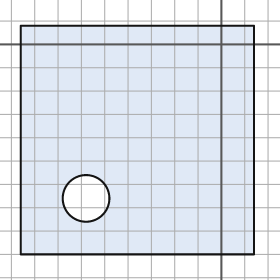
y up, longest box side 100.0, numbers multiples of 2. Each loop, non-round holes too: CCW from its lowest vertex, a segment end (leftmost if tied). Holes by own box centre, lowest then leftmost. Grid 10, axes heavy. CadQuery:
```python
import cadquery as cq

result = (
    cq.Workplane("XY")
    .moveTo(-86.0, -90.0)
    .lineTo(14.0, -90.0)
    .lineTo(14.0, 8.0)
    .lineTo(-86.0, 8.0)
    .close()
    .moveTo(-58.0, -66.0)
    .circle(10.0)
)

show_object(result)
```